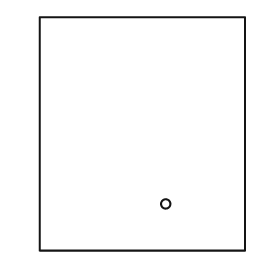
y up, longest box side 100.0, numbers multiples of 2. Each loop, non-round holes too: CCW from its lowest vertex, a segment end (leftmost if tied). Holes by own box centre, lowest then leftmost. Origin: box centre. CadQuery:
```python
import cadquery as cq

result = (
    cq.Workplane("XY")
    .moveTo(-44.0, -50.0)
    .lineTo(44.0, -50.0)
    .lineTo(44.0, 50.0)
    .lineTo(-44.0, 50.0)
    .close()
    .moveTo(10.0, -30.0)
    .circle(2.0)
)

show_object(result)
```